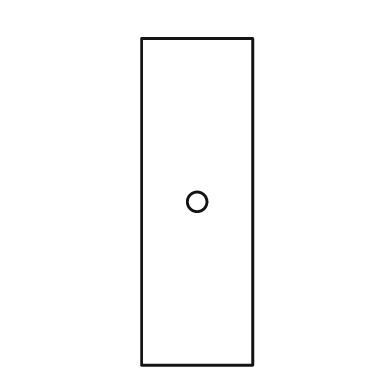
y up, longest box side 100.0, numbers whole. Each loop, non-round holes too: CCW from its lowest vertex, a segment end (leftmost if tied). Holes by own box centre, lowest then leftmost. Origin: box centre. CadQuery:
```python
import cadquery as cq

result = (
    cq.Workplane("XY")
    .moveTo(-17.0, -50.0)
    .lineTo(17.0, -50.0)
    .lineTo(17.0, 50.0)
    .lineTo(-17.0, 50.0)
    .close()
    .moveTo(0.0, 0.0)
    .circle(3.0)
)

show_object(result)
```